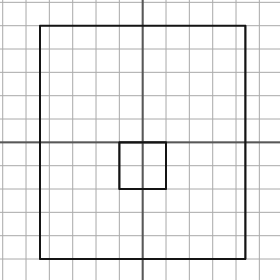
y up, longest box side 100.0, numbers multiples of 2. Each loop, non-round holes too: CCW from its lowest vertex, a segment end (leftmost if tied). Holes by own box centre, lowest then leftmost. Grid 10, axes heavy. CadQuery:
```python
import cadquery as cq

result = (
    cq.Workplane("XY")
    .moveTo(-44.0, -50.0)
    .lineTo(44.0, -50.0)
    .lineTo(44.0, 50.0)
    .lineTo(-44.0, 50.0)
    .close()
    .moveTo(-10.0, -20.0)
    .lineTo(10.0, -20.0)
    .lineTo(10.0, 0.0)
    .lineTo(-10.0, 0.0)
    .close()
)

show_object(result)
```